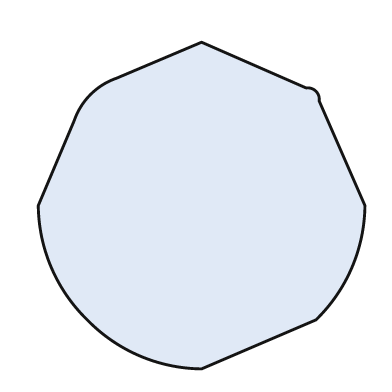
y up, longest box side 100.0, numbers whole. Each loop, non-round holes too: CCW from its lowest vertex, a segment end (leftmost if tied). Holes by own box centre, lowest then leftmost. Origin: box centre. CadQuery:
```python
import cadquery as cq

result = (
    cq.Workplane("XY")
    .moveTo(0.0, -50.0)
    .lineTo(35.0, -35.0)
    .threePointArc((46.0, -19.0), (50.0, 0.0))
    .lineTo(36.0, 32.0)
    .threePointArc((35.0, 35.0), (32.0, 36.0))
    .lineTo(0.0, 50.0)
    .lineTo(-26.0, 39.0)
    .threePointArc((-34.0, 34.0), (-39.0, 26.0))
    .lineTo(-50.0, 0.0)
    .threePointArc((-46.0, -19.0), (-35.0, -35.0))
    .threePointArc((-19.0, -46.0), (0.0, -50.0))
    .close()
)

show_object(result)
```